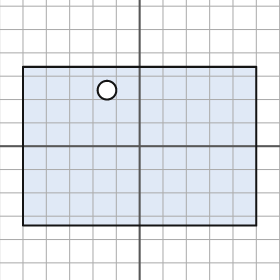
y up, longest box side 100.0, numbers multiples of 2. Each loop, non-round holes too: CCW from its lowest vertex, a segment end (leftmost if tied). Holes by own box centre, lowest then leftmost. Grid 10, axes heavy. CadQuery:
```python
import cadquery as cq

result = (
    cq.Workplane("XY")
    .moveTo(-50.0, -34.0)
    .lineTo(50.0, -34.0)
    .lineTo(50.0, 34.0)
    .lineTo(-50.0, 34.0)
    .close()
    .moveTo(-14.0, 24.0)
    .circle(4.0)
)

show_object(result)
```